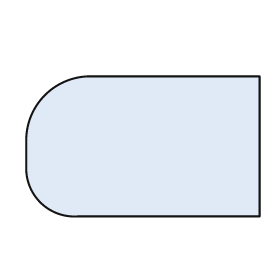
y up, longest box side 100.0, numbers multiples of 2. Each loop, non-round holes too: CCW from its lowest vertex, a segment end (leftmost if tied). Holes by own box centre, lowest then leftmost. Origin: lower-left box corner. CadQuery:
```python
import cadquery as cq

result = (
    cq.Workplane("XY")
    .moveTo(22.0, 0.0)
    .lineTo(100.0, 0.0)
    .lineTo(100.0, 60.0)
    .lineTo(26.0, 60.0)
    .threePointArc((8.0, 52.0), (0.0, 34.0))
    .lineTo(0.0, 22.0)
    .threePointArc((6.0, 6.0), (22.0, 0.0))
    .close()
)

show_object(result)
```